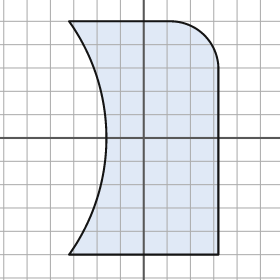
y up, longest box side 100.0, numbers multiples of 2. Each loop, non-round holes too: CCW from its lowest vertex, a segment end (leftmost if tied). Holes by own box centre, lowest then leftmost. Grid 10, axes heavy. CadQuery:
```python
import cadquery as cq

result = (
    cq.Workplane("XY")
    .moveTo(-32.0, -50.0)
    .lineTo(32.0, -50.0)
    .lineTo(32.0, 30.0)
    .threePointArc((26.0, 44.0), (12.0, 50.0))
    .lineTo(-32.0, 50.0)
    .threePointArc((-16.0, 0.0), (-32.0, -50.0))
    .close()
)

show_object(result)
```